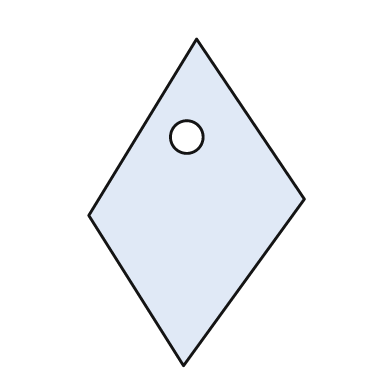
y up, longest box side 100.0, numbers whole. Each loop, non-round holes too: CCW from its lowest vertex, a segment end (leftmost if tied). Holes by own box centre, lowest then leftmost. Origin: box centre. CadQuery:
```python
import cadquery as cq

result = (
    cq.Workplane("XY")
    .moveTo(-4.0, -50.0)
    .lineTo(33.0, 1.0)
    .lineTo(0.0, 50.0)
    .lineTo(-33.0, -4.0)
    .close()
    .moveTo(-3.0, 20.0)
    .circle(5.0)
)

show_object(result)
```